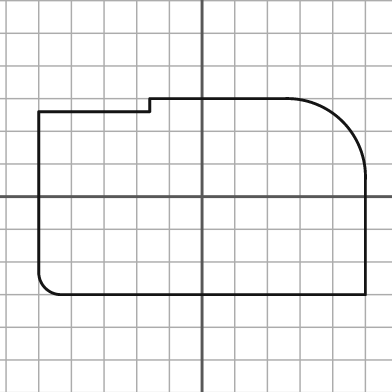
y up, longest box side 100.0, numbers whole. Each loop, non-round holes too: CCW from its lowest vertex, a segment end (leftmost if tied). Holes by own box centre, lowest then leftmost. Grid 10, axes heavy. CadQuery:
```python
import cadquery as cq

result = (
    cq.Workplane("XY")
    .moveTo(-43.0, -30.0)
    .lineTo(50.0, -30.0)
    .lineTo(50.0, 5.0)
    .threePointArc((43.0, 23.0), (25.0, 30.0))
    .lineTo(-16.0, 30.0)
    .lineTo(-16.0, 26.0)
    .lineTo(-50.0, 26.0)
    .lineTo(-50.0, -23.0)
    .threePointArc((-48.0, -28.0), (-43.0, -30.0))
    .close()
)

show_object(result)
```